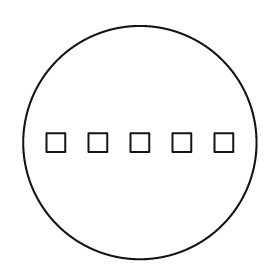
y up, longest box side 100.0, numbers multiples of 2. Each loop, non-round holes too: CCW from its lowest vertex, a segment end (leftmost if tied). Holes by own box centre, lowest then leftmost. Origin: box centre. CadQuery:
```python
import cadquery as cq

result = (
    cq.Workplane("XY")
    .moveTo(0.0, 0.0)
    .circle(50.0)
    .moveTo(-40.0, -4.0)
    .lineTo(-32.0, -4.0)
    .lineTo(-32.0, 4.0)
    .lineTo(-40.0, 4.0)
    .close()
    .moveTo(-22.0, -4.0)
    .lineTo(-14.0, -4.0)
    .lineTo(-14.0, 4.0)
    .lineTo(-22.0, 4.0)
    .close()
    .moveTo(-4.0, -4.0)
    .lineTo(4.0, -4.0)
    .lineTo(4.0, 4.0)
    .lineTo(-4.0, 4.0)
    .close()
    .moveTo(14.0, -4.0)
    .lineTo(22.0, -4.0)
    .lineTo(22.0, 4.0)
    .lineTo(14.0, 4.0)
    .close()
    .moveTo(32.0, -4.0)
    .lineTo(40.0, -4.0)
    .lineTo(40.0, 4.0)
    .lineTo(32.0, 4.0)
    .close()
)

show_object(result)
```